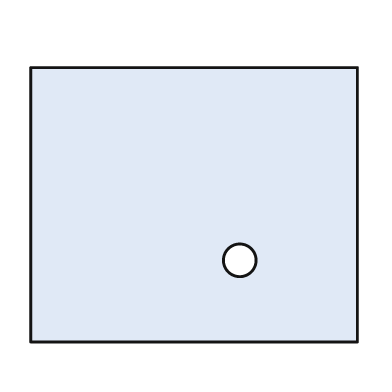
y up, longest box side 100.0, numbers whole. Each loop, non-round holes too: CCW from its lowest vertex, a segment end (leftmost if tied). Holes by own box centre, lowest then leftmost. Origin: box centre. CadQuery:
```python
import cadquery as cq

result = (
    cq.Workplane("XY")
    .moveTo(-50.0, -42.0)
    .lineTo(50.0, -42.0)
    .lineTo(50.0, 42.0)
    .lineTo(-50.0, 42.0)
    .close()
    .moveTo(14.0, -17.0)
    .circle(5.0)
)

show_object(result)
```